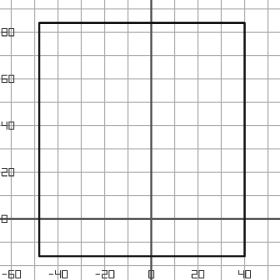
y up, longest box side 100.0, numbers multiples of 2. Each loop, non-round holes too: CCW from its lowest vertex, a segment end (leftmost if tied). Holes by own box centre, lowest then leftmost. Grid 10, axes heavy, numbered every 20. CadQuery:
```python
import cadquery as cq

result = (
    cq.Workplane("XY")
    .moveTo(-48.0, -16.0)
    .lineTo(40.0, -16.0)
    .lineTo(40.0, 84.0)
    .lineTo(-48.0, 84.0)
    .close()
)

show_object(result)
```